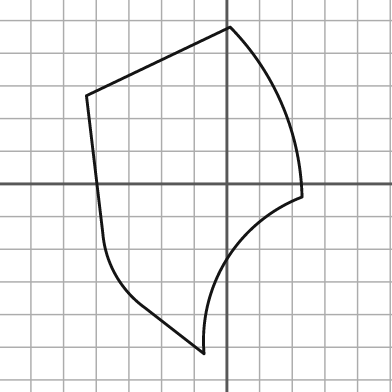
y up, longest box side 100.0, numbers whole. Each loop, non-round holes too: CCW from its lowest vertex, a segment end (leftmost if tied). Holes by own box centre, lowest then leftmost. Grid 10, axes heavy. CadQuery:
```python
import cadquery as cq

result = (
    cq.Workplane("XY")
    .moveTo(-7.0, -52.0)
    .threePointArc((0.0, -23.0), (23.0, -4.0))
    .threePointArc((17.0, 24.0), (1.0, 48.0))
    .lineTo(-43.0, 27.0)
    .lineTo(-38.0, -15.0)
    .threePointArc((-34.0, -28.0), (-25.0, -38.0))
    .close()
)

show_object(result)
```